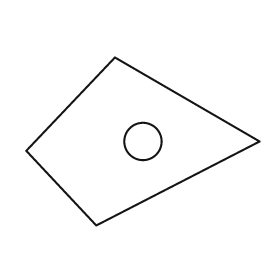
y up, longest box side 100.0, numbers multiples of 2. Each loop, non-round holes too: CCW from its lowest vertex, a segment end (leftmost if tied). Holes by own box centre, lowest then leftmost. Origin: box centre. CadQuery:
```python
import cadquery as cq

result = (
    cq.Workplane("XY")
    .moveTo(-20.0, -36.0)
    .lineTo(50.0, 0.0)
    .lineTo(-12.0, 36.0)
    .lineTo(-50.0, -4.0)
    .close()
    .moveTo(0.0, 0.0)
    .circle(8.0)
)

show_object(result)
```